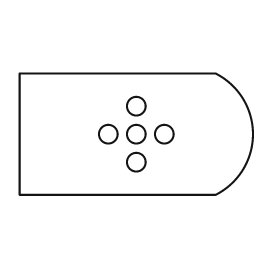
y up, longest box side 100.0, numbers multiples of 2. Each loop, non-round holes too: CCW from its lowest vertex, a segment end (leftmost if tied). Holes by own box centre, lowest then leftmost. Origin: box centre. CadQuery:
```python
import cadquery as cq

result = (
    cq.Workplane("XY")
    .moveTo(-50.0, -26.0)
    .lineTo(34.0, -26.0)
    .threePointArc((50.0, 0.0), (34.0, 26.0))
    .lineTo(-50.0, 26.0)
    .close()
    .moveTo(0.0, -12.0)
    .circle(4.0)
    .moveTo(-12.0, 0.0)
    .circle(4.0)
    .moveTo(0.0, 0.0)
    .circle(4.0)
    .moveTo(12.0, 0.0)
    .circle(4.0)
    .moveTo(0.0, 12.0)
    .circle(4.0)
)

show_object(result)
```